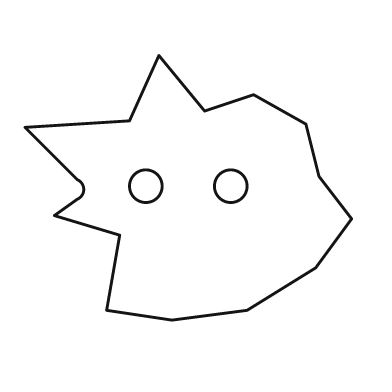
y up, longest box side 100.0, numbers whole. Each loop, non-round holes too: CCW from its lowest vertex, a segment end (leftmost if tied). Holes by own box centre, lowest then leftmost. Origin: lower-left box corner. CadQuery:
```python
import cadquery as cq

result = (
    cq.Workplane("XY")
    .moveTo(45.0, 0.0)
    .lineTo(68.0, 3.0)
    .lineTo(89.0, 16.0)
    .lineTo(100.0, 31.0)
    .lineTo(90.0, 44.0)
    .lineTo(86.0, 60.0)
    .lineTo(70.0, 69.0)
    .lineTo(55.0, 64.0)
    .lineTo(41.0, 81.0)
    .lineTo(32.0, 61.0)
    .lineTo(0.0, 59.0)
    .lineTo(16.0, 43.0)
    .threePointArc((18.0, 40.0), (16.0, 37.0))
    .lineTo(9.0, 32.0)
    .lineTo(29.0, 26.0)
    .lineTo(25.0, 3.0)
    .close()
    .moveTo(37.0, 41.0)
    .circle(5.0)
    .moveTo(63.0, 41.0)
    .circle(5.0)
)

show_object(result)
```